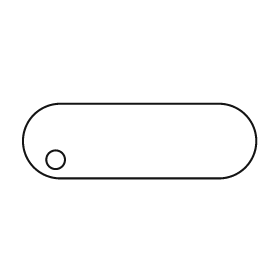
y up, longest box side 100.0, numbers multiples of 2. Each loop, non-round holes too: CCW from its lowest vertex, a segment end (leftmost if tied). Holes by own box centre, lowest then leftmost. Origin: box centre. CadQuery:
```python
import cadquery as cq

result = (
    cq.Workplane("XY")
    .moveTo(-34.0, -16.0)
    .lineTo(34.0, -16.0)
    .threePointArc((50.0, 0.0), (34.0, 16.0))
    .lineTo(-34.0, 16.0)
    .threePointArc((-50.0, 0.0), (-34.0, -16.0))
    .close()
    .moveTo(-36.0, -8.0)
    .circle(4.0)
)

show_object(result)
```